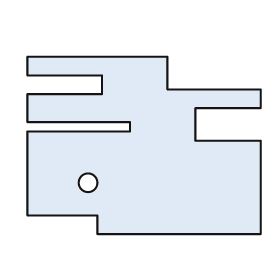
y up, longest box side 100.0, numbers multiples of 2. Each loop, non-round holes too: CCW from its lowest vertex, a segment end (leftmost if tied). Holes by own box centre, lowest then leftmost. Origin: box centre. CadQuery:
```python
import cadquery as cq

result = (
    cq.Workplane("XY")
    .moveTo(-20.0, -38.0)
    .lineTo(50.0, -38.0)
    .lineTo(50.0, 2.0)
    .lineTo(22.0, 2.0)
    .lineTo(22.0, 16.0)
    .lineTo(50.0, 16.0)
    .lineTo(50.0, 24.0)
    .lineTo(10.0, 24.0)
    .lineTo(10.0, 38.0)
    .lineTo(-50.0, 38.0)
    .lineTo(-50.0, 30.0)
    .lineTo(-18.0, 30.0)
    .lineTo(-18.0, 22.0)
    .lineTo(-50.0, 22.0)
    .lineTo(-50.0, 10.0)
    .lineTo(-6.0, 10.0)
    .lineTo(-6.0, 6.0)
    .lineTo(-50.0, 6.0)
    .lineTo(-50.0, -30.0)
    .lineTo(-20.0, -30.0)
    .close()
    .moveTo(-24.0, -16.0)
    .circle(4.0)
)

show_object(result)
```